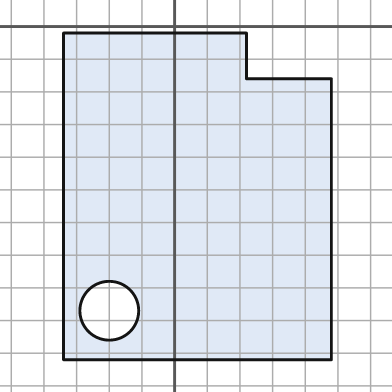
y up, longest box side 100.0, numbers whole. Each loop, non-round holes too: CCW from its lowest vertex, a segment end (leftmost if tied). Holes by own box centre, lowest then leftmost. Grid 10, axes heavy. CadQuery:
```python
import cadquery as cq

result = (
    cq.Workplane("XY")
    .moveTo(-34.0, -102.0)
    .lineTo(48.0, -102.0)
    .lineTo(48.0, -16.0)
    .lineTo(22.0, -16.0)
    .lineTo(22.0, -2.0)
    .lineTo(-34.0, -2.0)
    .close()
    .moveTo(-20.0, -87.0)
    .circle(9.0)
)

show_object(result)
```